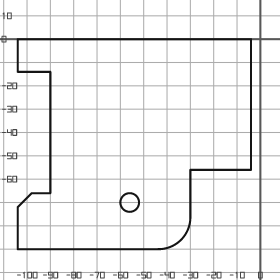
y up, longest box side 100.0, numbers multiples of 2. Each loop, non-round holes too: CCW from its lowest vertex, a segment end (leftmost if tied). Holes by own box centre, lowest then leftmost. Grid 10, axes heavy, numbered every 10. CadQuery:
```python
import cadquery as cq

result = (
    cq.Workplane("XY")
    .moveTo(-104.0, -90.0)
    .lineTo(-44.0, -90.0)
    .threePointArc((-34.0, -86.0), (-30.0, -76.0))
    .lineTo(-30.0, -56.0)
    .lineTo(-4.0, -56.0)
    .lineTo(-4.0, 0.0)
    .lineTo(-104.0, 0.0)
    .lineTo(-104.0, -14.0)
    .lineTo(-90.0, -14.0)
    .lineTo(-90.0, -66.0)
    .lineTo(-98.0, -66.0)
    .lineTo(-104.0, -72.0)
    .close()
    .moveTo(-56.0, -70.0)
    .circle(4.0)
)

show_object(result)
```